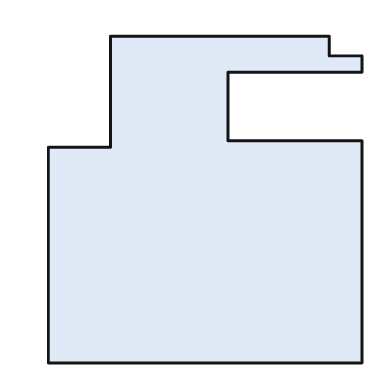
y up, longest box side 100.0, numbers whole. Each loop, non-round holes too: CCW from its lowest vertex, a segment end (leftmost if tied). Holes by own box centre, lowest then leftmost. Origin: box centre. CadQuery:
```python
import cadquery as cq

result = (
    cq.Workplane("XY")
    .moveTo(-48.0, -50.0)
    .lineTo(48.0, -50.0)
    .lineTo(48.0, 18.0)
    .lineTo(7.0, 18.0)
    .lineTo(7.0, 39.0)
    .lineTo(48.0, 39.0)
    .lineTo(48.0, 44.0)
    .lineTo(38.0, 44.0)
    .lineTo(38.0, 50.0)
    .lineTo(-29.0, 50.0)
    .lineTo(-29.0, 16.0)
    .lineTo(-48.0, 16.0)
    .close()
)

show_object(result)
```